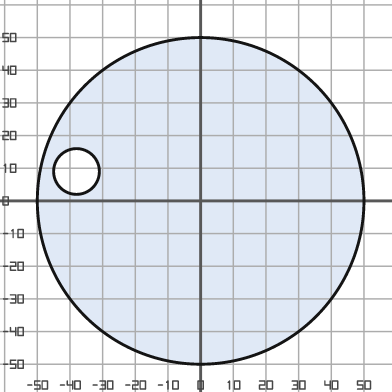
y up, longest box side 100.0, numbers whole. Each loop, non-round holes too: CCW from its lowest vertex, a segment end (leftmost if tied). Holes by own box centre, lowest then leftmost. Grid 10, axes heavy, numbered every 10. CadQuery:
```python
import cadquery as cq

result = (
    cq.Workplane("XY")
    .moveTo(0.0, 0.0)
    .circle(50.0)
    .moveTo(-38.0, 9.0)
    .circle(7.0)
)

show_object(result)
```